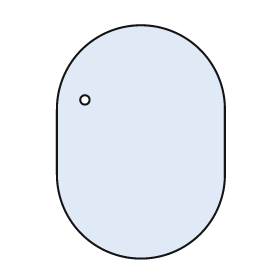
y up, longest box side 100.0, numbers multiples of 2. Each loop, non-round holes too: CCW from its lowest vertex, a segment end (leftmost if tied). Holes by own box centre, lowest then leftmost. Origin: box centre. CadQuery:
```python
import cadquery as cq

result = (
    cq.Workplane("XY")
    .moveTo(-36.0, -14.0)
    .threePointArc((0.0, -50.0), (36.0, -14.0))
    .lineTo(36.0, 14.0)
    .threePointArc((0.0, 50.0), (-36.0, 14.0))
    .close()
    .moveTo(-24.0, 18.0)
    .circle(2.0)
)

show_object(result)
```